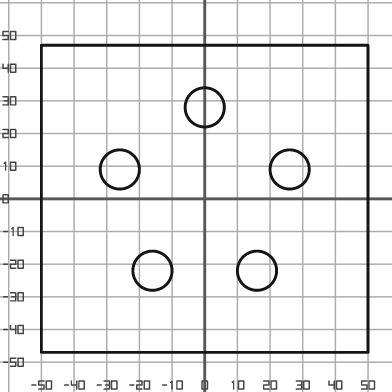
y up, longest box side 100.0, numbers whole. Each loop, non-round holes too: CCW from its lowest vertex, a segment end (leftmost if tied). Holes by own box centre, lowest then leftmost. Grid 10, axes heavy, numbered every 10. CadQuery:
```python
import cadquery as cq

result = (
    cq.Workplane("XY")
    .moveTo(-50.0, -47.0)
    .lineTo(50.0, -47.0)
    .lineTo(50.0, 47.0)
    .lineTo(-50.0, 47.0)
    .close()
    .moveTo(-16.0, -22.0)
    .circle(6.0)
    .moveTo(16.0, -22.0)
    .circle(6.0)
    .moveTo(-26.0, 9.0)
    .circle(6.0)
    .moveTo(26.0, 9.0)
    .circle(6.0)
    .moveTo(0.0, 28.0)
    .circle(6.0)
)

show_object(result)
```